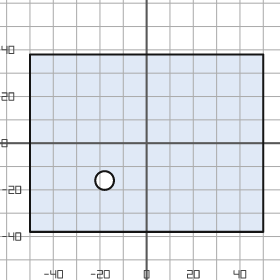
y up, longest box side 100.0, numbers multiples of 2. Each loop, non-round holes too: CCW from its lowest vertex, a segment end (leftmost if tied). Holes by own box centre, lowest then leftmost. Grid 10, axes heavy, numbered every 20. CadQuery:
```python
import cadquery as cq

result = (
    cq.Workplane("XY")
    .moveTo(-50.0, -38.0)
    .lineTo(50.0, -38.0)
    .lineTo(50.0, 38.0)
    .lineTo(-50.0, 38.0)
    .close()
    .moveTo(-18.0, -16.0)
    .circle(4.0)
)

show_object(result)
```